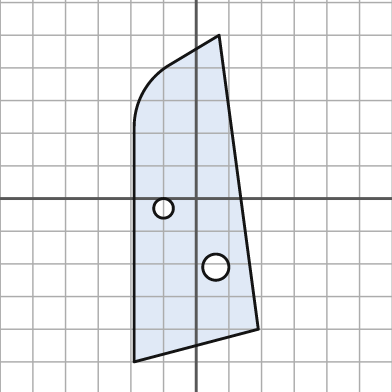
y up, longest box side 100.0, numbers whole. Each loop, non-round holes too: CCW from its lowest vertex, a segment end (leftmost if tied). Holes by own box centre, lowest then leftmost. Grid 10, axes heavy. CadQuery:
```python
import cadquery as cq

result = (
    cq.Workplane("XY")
    .moveTo(-19.0, -50.0)
    .lineTo(19.0, -40.0)
    .lineTo(7.0, 50.0)
    .lineTo(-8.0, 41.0)
    .threePointArc((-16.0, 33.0), (-19.0, 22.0))
    .close()
    .moveTo(6.0, -21.0)
    .circle(4.0)
    .moveTo(-10.0, -3.0)
    .circle(3.0)
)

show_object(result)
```